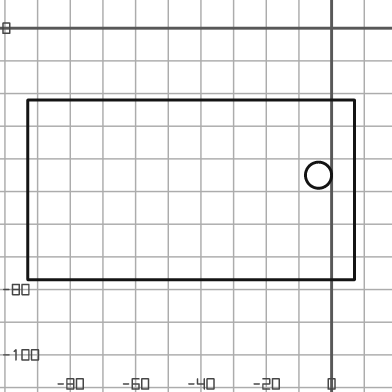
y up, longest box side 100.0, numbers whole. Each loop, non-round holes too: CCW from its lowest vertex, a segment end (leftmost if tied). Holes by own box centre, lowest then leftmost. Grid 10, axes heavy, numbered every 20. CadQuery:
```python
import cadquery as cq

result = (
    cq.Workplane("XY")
    .moveTo(-93.0, -77.0)
    .lineTo(7.0, -77.0)
    .lineTo(7.0, -22.0)
    .lineTo(-93.0, -22.0)
    .close()
    .moveTo(-4.0, -45.0)
    .circle(4.0)
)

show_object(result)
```